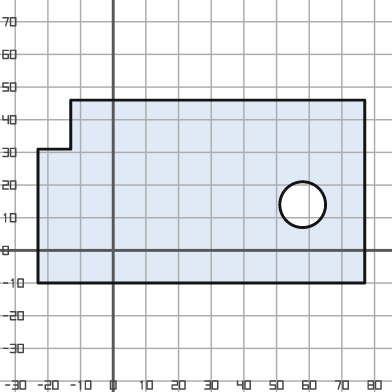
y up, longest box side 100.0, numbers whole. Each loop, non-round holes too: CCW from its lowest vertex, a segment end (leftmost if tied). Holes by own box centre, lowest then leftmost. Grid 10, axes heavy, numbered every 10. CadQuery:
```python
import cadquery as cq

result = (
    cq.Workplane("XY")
    .moveTo(-23.0, -10.0)
    .lineTo(77.0, -10.0)
    .lineTo(77.0, 46.0)
    .lineTo(-13.0, 46.0)
    .lineTo(-13.0, 31.0)
    .lineTo(-23.0, 31.0)
    .close()
    .moveTo(58.0, 14.0)
    .circle(7.0)
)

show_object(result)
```